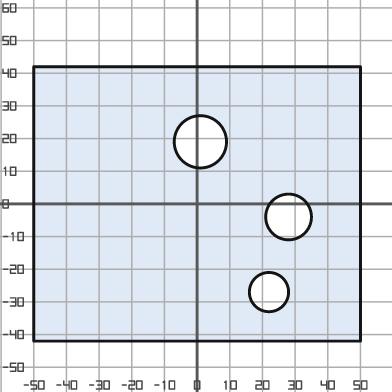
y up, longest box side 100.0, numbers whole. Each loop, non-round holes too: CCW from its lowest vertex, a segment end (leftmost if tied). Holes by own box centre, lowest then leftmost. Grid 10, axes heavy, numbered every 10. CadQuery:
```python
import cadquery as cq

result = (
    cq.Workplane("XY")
    .moveTo(-50.0, -42.0)
    .lineTo(50.0, -42.0)
    .lineTo(50.0, 42.0)
    .lineTo(-50.0, 42.0)
    .close()
    .moveTo(22.0, -27.0)
    .circle(6.0)
    .moveTo(28.0, -4.0)
    .circle(7.0)
    .moveTo(1.0, 19.0)
    .circle(8.0)
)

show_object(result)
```